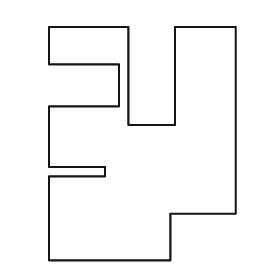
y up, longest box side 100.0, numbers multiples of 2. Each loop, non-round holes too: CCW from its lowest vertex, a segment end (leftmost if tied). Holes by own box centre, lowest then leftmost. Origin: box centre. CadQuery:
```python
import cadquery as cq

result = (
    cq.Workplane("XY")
    .moveTo(-40.0, -50.0)
    .lineTo(12.0, -50.0)
    .lineTo(12.0, -30.0)
    .lineTo(40.0, -30.0)
    .lineTo(40.0, 50.0)
    .lineTo(14.0, 50.0)
    .lineTo(14.0, 8.0)
    .lineTo(-6.0, 8.0)
    .lineTo(-6.0, 50.0)
    .lineTo(-40.0, 50.0)
    .lineTo(-40.0, 34.0)
    .lineTo(-10.0, 34.0)
    .lineTo(-10.0, 16.0)
    .lineTo(-40.0, 16.0)
    .lineTo(-40.0, -10.0)
    .lineTo(-16.0, -10.0)
    .lineTo(-16.0, -14.0)
    .lineTo(-40.0, -14.0)
    .close()
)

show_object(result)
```